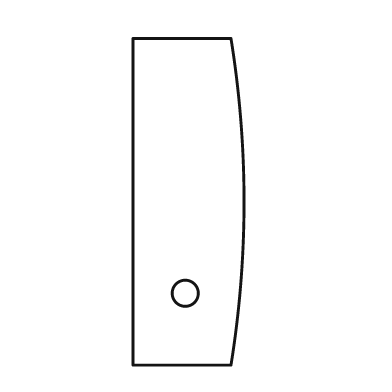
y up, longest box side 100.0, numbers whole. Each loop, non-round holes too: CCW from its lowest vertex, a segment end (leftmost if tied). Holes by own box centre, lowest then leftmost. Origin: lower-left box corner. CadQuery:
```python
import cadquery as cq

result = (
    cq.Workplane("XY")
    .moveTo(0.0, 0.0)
    .lineTo(30.0, 0.0)
    .threePointArc((34.0, 50.0), (30.0, 100.0))
    .lineTo(0.0, 100.0)
    .close()
    .moveTo(16.0, 22.0)
    .circle(4.0)
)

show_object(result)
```